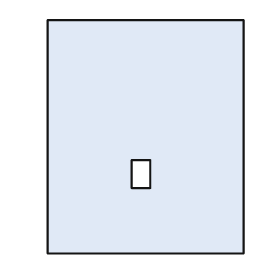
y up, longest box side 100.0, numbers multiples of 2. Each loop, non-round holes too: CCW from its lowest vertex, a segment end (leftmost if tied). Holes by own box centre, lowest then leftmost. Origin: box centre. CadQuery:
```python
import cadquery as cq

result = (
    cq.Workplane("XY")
    .moveTo(-42.0, -50.0)
    .lineTo(42.0, -50.0)
    .lineTo(42.0, 50.0)
    .lineTo(-42.0, 50.0)
    .close()
    .moveTo(-6.0, -22.0)
    .lineTo(2.0, -22.0)
    .lineTo(2.0, -10.0)
    .lineTo(-6.0, -10.0)
    .close()
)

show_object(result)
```